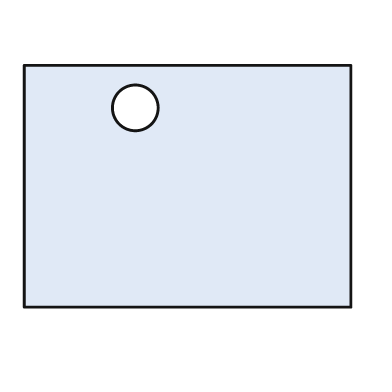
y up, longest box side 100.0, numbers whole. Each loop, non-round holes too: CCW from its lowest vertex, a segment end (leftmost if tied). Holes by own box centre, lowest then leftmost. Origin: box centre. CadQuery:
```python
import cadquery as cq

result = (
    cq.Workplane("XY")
    .moveTo(-50.0, -37.0)
    .lineTo(50.0, -37.0)
    .lineTo(50.0, 37.0)
    .lineTo(-50.0, 37.0)
    .close()
    .moveTo(-16.0, 24.0)
    .circle(7.0)
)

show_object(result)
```